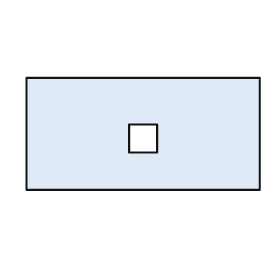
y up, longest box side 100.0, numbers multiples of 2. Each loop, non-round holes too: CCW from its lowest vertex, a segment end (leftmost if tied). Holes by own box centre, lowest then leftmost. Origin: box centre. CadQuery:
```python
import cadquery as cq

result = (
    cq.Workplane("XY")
    .moveTo(-50.0, -24.0)
    .lineTo(50.0, -24.0)
    .lineTo(50.0, 24.0)
    .lineTo(-50.0, 24.0)
    .close()
    .moveTo(-6.0, -8.0)
    .lineTo(6.0, -8.0)
    .lineTo(6.0, 4.0)
    .lineTo(-6.0, 4.0)
    .close()
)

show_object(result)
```